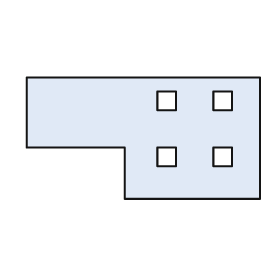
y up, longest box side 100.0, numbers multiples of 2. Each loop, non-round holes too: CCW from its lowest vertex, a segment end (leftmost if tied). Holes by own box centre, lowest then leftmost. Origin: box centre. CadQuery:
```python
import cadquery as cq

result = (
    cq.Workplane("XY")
    .moveTo(-8.0, -26.0)
    .lineTo(50.0, -26.0)
    .lineTo(50.0, 26.0)
    .lineTo(-50.0, 26.0)
    .lineTo(-50.0, -4.0)
    .lineTo(-8.0, -4.0)
    .close()
    .moveTo(6.0, -12.0)
    .lineTo(14.0, -12.0)
    .lineTo(14.0, -4.0)
    .lineTo(6.0, -4.0)
    .close()
    .moveTo(30.0, -12.0)
    .lineTo(38.0, -12.0)
    .lineTo(38.0, -4.0)
    .lineTo(30.0, -4.0)
    .close()
    .moveTo(6.0, 12.0)
    .lineTo(14.0, 12.0)
    .lineTo(14.0, 20.0)
    .lineTo(6.0, 20.0)
    .close()
    .moveTo(30.0, 12.0)
    .lineTo(38.0, 12.0)
    .lineTo(38.0, 20.0)
    .lineTo(30.0, 20.0)
    .close()
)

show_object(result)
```